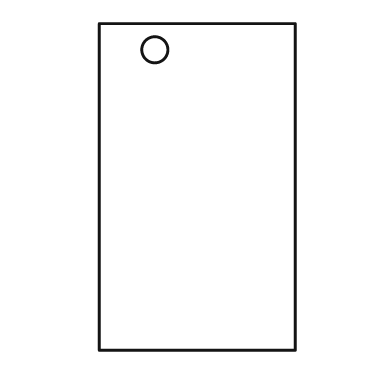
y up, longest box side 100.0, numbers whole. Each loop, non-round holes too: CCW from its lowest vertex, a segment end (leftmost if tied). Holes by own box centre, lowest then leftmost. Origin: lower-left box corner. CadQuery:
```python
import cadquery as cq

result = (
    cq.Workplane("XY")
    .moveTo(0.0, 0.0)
    .lineTo(60.0, 0.0)
    .lineTo(60.0, 100.0)
    .lineTo(0.0, 100.0)
    .close()
    .moveTo(17.0, 92.0)
    .circle(4.0)
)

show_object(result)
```